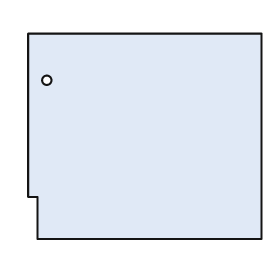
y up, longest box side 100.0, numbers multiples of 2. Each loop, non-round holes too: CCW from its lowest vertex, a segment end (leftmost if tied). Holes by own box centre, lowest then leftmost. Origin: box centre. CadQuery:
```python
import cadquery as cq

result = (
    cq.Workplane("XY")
    .moveTo(-46.0, -44.0)
    .lineTo(50.0, -44.0)
    .lineTo(50.0, 44.0)
    .lineTo(-50.0, 44.0)
    .lineTo(-50.0, -26.0)
    .lineTo(-46.0, -26.0)
    .close()
    .moveTo(-42.0, 24.0)
    .circle(2.0)
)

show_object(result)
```